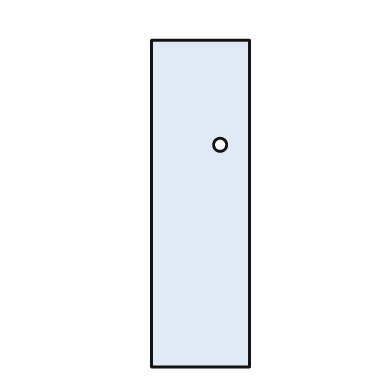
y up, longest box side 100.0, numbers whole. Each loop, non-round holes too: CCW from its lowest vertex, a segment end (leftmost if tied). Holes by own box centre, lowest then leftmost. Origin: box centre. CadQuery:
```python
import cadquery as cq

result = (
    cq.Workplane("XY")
    .moveTo(-15.0, -50.0)
    .lineTo(15.0, -50.0)
    .lineTo(15.0, 50.0)
    .lineTo(-15.0, 50.0)
    .close()
    .moveTo(6.0, 18.0)
    .circle(2.0)
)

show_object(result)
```